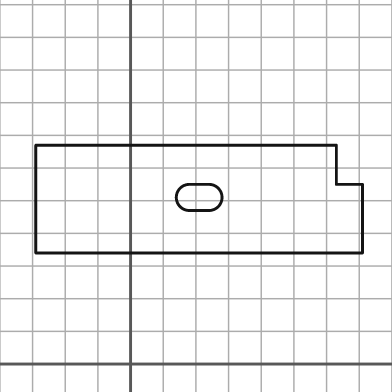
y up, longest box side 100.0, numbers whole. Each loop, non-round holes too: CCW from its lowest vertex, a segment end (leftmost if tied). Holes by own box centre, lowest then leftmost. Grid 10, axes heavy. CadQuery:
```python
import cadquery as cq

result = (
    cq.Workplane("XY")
    .moveTo(-29.0, 34.0)
    .lineTo(71.0, 34.0)
    .lineTo(71.0, 55.0)
    .lineTo(63.0, 55.0)
    .lineTo(63.0, 67.0)
    .lineTo(-29.0, 67.0)
    .close()
    .moveTo(18.0, 47.0)
    .lineTo(24.0, 47.0)
    .threePointArc((28.0, 51.0), (24.0, 55.0))
    .lineTo(18.0, 55.0)
    .threePointArc((14.0, 51.0), (18.0, 47.0))
    .close()
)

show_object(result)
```